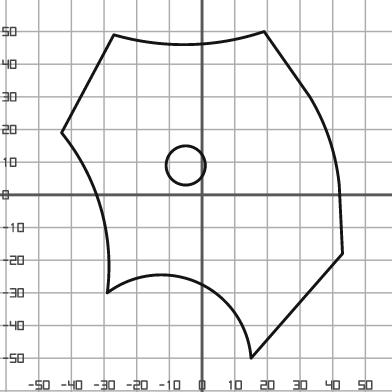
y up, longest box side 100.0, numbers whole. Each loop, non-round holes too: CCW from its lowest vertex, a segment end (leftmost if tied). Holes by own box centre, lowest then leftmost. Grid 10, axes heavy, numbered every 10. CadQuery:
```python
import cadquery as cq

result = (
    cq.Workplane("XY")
    .moveTo(15.0, -50.0)
    .lineTo(43.0, -18.0)
    .lineTo(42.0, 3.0)
    .threePointArc((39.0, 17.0), (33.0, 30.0))
    .lineTo(19.0, 50.0)
    .threePointArc((-4.0, 46.0), (-27.0, 49.0))
    .lineTo(-43.0, 19.0)
    .threePointArc((-31.0, -4.0), (-29.0, -30.0))
    .threePointArc((-1.0, -27.0), (15.0, -50.0))
    .close()
    .moveTo(-5.0, 9.0)
    .circle(6.0)
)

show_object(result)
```